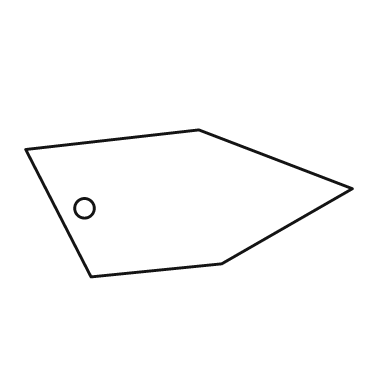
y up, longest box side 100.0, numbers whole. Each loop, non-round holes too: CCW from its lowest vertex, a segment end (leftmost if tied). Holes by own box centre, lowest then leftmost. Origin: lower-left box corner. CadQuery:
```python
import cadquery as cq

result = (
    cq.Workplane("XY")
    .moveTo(20.0, 0.0)
    .lineTo(60.0, 4.0)
    .lineTo(100.0, 27.0)
    .lineTo(53.0, 45.0)
    .lineTo(0.0, 39.0)
    .close()
    .moveTo(18.0, 21.0)
    .circle(3.0)
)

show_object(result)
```